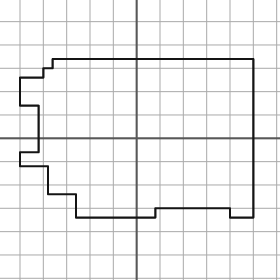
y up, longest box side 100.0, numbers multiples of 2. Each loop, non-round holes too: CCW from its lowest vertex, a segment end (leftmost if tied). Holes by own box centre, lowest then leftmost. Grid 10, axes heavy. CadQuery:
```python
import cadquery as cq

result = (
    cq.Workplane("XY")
    .moveTo(-26.0, -34.0)
    .lineTo(8.0, -34.0)
    .lineTo(8.0, -30.0)
    .lineTo(40.0, -30.0)
    .lineTo(40.0, -34.0)
    .lineTo(50.0, -34.0)
    .lineTo(50.0, 34.0)
    .lineTo(-36.0, 34.0)
    .lineTo(-36.0, 30.0)
    .lineTo(-40.0, 30.0)
    .lineTo(-40.0, 26.0)
    .lineTo(-50.0, 26.0)
    .lineTo(-50.0, 14.0)
    .lineTo(-42.0, 14.0)
    .lineTo(-42.0, -6.0)
    .lineTo(-50.0, -6.0)
    .lineTo(-50.0, -12.0)
    .lineTo(-38.0, -12.0)
    .lineTo(-38.0, -24.0)
    .lineTo(-26.0, -24.0)
    .close()
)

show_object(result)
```